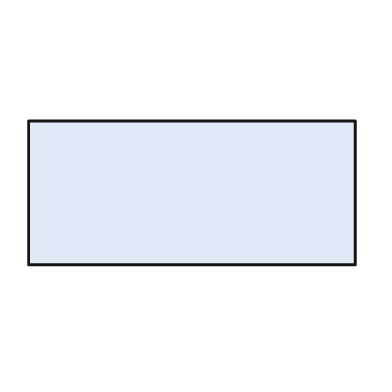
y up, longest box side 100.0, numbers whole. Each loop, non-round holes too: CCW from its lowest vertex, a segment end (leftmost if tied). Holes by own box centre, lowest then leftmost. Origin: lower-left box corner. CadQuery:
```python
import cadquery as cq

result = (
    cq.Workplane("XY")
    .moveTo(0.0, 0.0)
    .lineTo(100.0, 0.0)
    .lineTo(100.0, 44.0)
    .lineTo(0.0, 44.0)
    .close()
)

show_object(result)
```